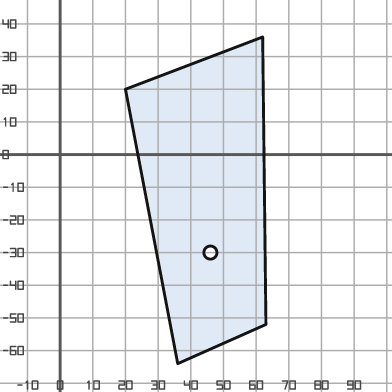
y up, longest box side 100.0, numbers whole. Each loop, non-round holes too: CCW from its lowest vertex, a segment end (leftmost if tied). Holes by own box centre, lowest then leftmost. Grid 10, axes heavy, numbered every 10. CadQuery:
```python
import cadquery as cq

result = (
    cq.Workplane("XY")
    .moveTo(36.0, -64.0)
    .lineTo(63.0, -52.0)
    .lineTo(62.0, 36.0)
    .lineTo(20.0, 20.0)
    .close()
    .moveTo(46.0, -30.0)
    .circle(2.0)
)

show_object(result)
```